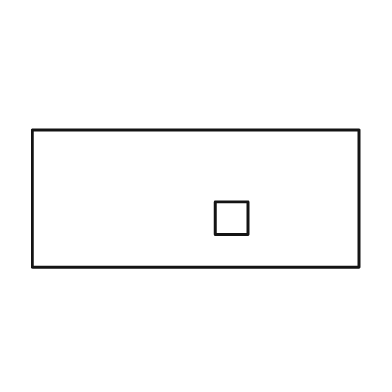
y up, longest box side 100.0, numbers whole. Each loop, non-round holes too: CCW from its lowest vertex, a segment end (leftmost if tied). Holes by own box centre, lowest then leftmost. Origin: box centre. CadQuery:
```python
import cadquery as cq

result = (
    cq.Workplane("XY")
    .moveTo(-50.0, -21.0)
    .lineTo(50.0, -21.0)
    .lineTo(50.0, 21.0)
    .lineTo(-50.0, 21.0)
    .close()
    .moveTo(6.0, -11.0)
    .lineTo(16.0, -11.0)
    .lineTo(16.0, -1.0)
    .lineTo(6.0, -1.0)
    .close()
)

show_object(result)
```